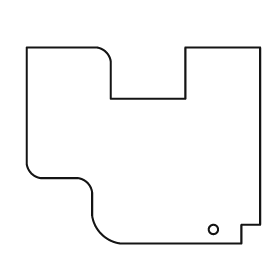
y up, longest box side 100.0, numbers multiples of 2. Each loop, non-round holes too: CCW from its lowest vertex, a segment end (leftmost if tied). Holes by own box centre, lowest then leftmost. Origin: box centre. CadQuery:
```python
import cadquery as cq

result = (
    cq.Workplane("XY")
    .moveTo(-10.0, -42.0)
    .lineTo(42.0, -42.0)
    .lineTo(42.0, -34.0)
    .lineTo(50.0, -34.0)
    .lineTo(50.0, 42.0)
    .lineTo(18.0, 42.0)
    .lineTo(18.0, 20.0)
    .lineTo(-14.0, 20.0)
    .lineTo(-14.0, 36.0)
    .threePointArc((-16.0, 40.0), (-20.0, 42.0))
    .lineTo(-50.0, 42.0)
    .lineTo(-50.0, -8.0)
    .threePointArc((-48.0, -12.0), (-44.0, -14.0))
    .lineTo(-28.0, -14.0)
    .threePointArc((-24.0, -16.0), (-22.0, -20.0))
    .lineTo(-22.0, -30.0)
    .threePointArc((-18.0, -38.0), (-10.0, -42.0))
    .close()
    .moveTo(30.0, -36.0)
    .circle(2.0)
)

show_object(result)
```